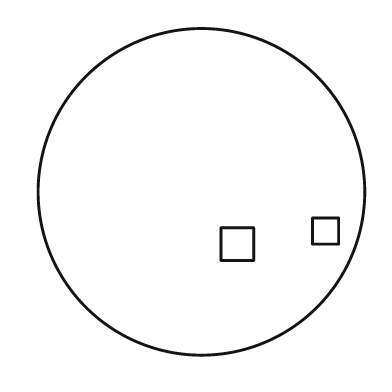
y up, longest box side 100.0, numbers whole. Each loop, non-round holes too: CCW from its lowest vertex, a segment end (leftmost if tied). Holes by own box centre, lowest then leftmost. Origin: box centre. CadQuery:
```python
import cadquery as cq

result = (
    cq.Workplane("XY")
    .moveTo(0.0, 0.0)
    .circle(50.0)
    .moveTo(6.0, -21.0)
    .lineTo(16.0, -21.0)
    .lineTo(16.0, -11.0)
    .lineTo(6.0, -11.0)
    .close()
    .moveTo(34.0, -16.0)
    .lineTo(42.0, -16.0)
    .lineTo(42.0, -8.0)
    .lineTo(34.0, -8.0)
    .close()
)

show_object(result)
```